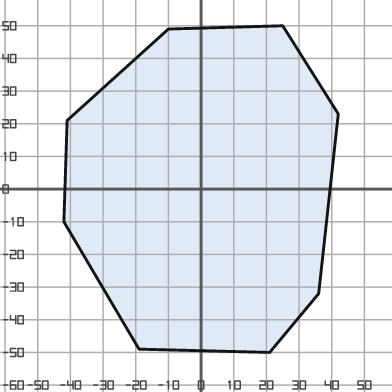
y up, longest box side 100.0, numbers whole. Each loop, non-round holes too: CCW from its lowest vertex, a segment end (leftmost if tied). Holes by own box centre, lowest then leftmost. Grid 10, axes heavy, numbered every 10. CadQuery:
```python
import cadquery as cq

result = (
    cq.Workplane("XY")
    .moveTo(21.0, -50.0)
    .lineTo(36.0, -32.0)
    .lineTo(42.0, 23.0)
    .lineTo(25.0, 50.0)
    .lineTo(-10.0, 49.0)
    .lineTo(-41.0, 21.0)
    .lineTo(-42.0, -10.0)
    .lineTo(-19.0, -49.0)
    .close()
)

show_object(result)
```